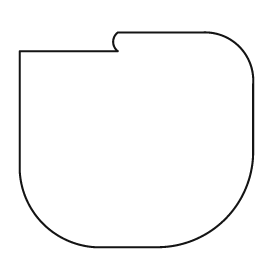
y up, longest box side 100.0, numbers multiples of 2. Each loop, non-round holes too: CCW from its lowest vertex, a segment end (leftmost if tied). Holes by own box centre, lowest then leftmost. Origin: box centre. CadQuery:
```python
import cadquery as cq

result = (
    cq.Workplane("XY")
    .moveTo(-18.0, -46.0)
    .lineTo(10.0, -46.0)
    .threePointArc((38.0, -34.0), (50.0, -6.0))
    .lineTo(50.0, 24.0)
    .threePointArc((44.0, 40.0), (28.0, 46.0))
    .lineTo(-8.0, 46.0)
    .threePointArc((-10.0, 42.0), (-8.0, 38.0))
    .lineTo(-50.0, 38.0)
    .lineTo(-50.0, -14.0)
    .threePointArc((-40.0, -36.0), (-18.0, -46.0))
    .close()
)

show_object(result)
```